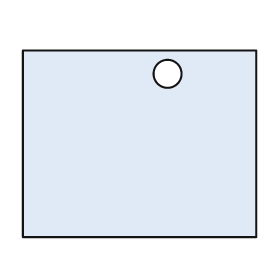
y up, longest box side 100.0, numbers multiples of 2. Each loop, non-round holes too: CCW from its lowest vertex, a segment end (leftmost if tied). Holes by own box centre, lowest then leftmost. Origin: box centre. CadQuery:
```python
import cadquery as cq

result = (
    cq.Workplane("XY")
    .moveTo(-50.0, -40.0)
    .lineTo(50.0, -40.0)
    .lineTo(50.0, 40.0)
    .lineTo(-50.0, 40.0)
    .close()
    .moveTo(12.0, 30.0)
    .circle(6.0)
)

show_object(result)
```